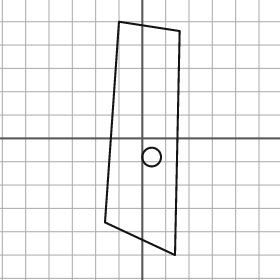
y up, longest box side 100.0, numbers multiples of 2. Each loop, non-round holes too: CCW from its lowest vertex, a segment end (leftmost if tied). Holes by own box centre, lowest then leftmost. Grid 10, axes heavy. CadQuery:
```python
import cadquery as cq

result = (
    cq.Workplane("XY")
    .moveTo(14.0, -50.0)
    .lineTo(16.0, 46.0)
    .lineTo(-10.0, 50.0)
    .lineTo(-16.0, -36.0)
    .close()
    .moveTo(4.0, -8.0)
    .circle(4.0)
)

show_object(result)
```